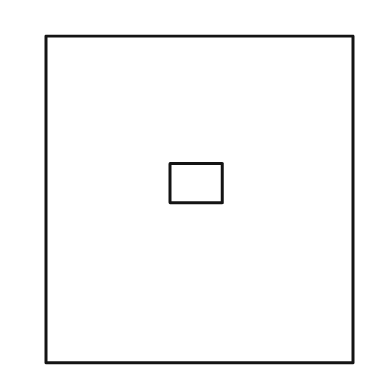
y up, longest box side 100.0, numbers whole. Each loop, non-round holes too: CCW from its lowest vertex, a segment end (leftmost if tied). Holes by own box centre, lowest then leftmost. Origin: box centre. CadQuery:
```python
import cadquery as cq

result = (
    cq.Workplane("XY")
    .moveTo(-47.0, -50.0)
    .lineTo(47.0, -50.0)
    .lineTo(47.0, 50.0)
    .lineTo(-47.0, 50.0)
    .close()
    .moveTo(-9.0, -1.0)
    .lineTo(7.0, -1.0)
    .lineTo(7.0, 11.0)
    .lineTo(-9.0, 11.0)
    .close()
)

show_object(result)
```